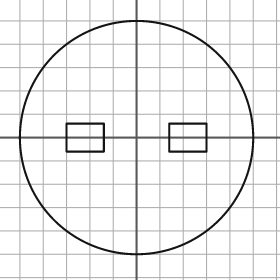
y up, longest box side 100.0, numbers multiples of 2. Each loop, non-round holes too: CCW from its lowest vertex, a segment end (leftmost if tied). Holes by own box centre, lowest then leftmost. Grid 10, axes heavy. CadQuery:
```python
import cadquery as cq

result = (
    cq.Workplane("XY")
    .moveTo(0.0, 0.0)
    .circle(50.0)
    .moveTo(-30.0, -6.0)
    .lineTo(-14.0, -6.0)
    .lineTo(-14.0, 6.0)
    .lineTo(-30.0, 6.0)
    .close()
    .moveTo(14.0, -6.0)
    .lineTo(30.0, -6.0)
    .lineTo(30.0, 6.0)
    .lineTo(14.0, 6.0)
    .close()
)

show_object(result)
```